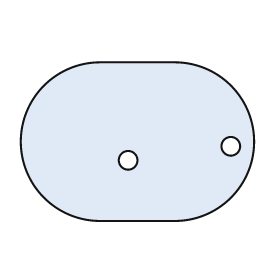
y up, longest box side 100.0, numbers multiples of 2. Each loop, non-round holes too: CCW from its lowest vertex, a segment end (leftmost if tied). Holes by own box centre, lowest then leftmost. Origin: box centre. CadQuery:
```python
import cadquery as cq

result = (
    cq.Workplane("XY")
    .moveTo(-16.0, -34.0)
    .lineTo(16.0, -34.0)
    .threePointArc((50.0, 0.0), (16.0, 34.0))
    .lineTo(-16.0, 34.0)
    .threePointArc((-50.0, 0.0), (-16.0, -34.0))
    .close()
    .moveTo(-4.0, -8.0)
    .circle(4.0)
    .moveTo(40.0, -2.0)
    .circle(4.0)
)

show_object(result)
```